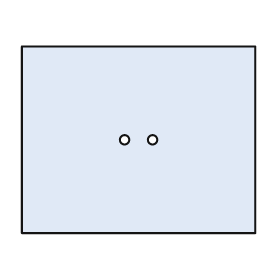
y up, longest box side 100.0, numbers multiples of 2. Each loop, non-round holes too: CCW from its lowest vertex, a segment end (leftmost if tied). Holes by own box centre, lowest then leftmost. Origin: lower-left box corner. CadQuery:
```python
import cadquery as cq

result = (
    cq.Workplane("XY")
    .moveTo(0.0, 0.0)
    .lineTo(100.0, 0.0)
    .lineTo(100.0, 80.0)
    .lineTo(0.0, 80.0)
    .close()
    .moveTo(44.0, 40.0)
    .circle(2.0)
    .moveTo(56.0, 40.0)
    .circle(2.0)
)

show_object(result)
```